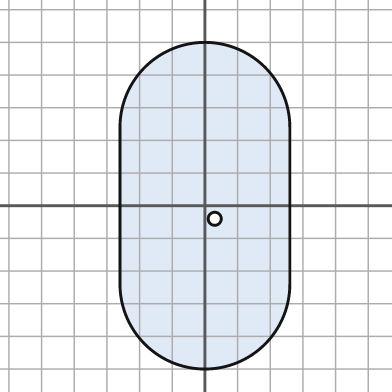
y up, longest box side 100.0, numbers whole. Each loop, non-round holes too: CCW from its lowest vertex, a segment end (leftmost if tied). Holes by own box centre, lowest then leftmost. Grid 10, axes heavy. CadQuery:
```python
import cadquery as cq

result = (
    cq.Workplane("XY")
    .moveTo(-26.0, -24.0)
    .threePointArc((0.0, -50.0), (26.0, -24.0))
    .lineTo(26.0, 24.0)
    .threePointArc((0.0, 50.0), (-26.0, 24.0))
    .close()
    .moveTo(3.0, -4.0)
    .circle(2.0)
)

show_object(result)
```